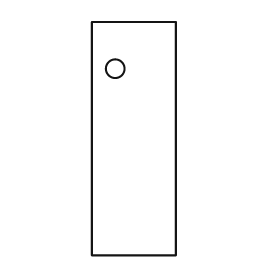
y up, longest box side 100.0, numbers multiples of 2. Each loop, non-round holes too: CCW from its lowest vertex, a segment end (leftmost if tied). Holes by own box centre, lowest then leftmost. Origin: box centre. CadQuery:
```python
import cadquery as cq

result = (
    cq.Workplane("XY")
    .moveTo(-18.0, -50.0)
    .lineTo(18.0, -50.0)
    .lineTo(18.0, 50.0)
    .lineTo(-18.0, 50.0)
    .close()
    .moveTo(-8.0, 30.0)
    .circle(4.0)
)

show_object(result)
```